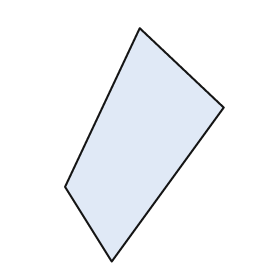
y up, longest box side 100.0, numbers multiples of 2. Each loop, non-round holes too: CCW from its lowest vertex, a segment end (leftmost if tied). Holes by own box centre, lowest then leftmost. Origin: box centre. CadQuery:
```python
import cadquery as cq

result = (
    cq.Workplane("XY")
    .moveTo(-14.0, -50.0)
    .lineTo(34.0, 16.0)
    .lineTo(-2.0, 50.0)
    .lineTo(-34.0, -18.0)
    .close()
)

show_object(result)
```